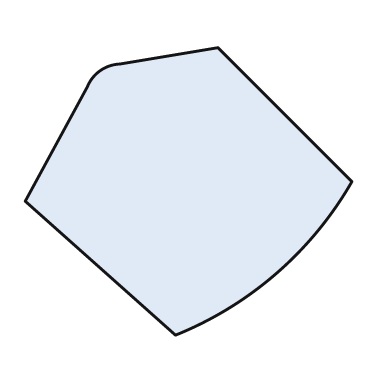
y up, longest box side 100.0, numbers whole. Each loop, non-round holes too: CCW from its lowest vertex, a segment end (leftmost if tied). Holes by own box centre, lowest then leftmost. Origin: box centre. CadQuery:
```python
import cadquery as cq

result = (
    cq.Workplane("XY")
    .moveTo(-4.0, -44.0)
    .threePointArc((27.0, -25.0), (50.0, 3.0))
    .lineTo(9.0, 44.0)
    .lineTo(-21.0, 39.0)
    .threePointArc((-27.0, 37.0), (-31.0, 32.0))
    .lineTo(-50.0, -3.0)
    .close()
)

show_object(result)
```